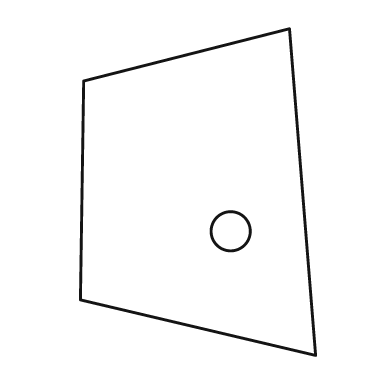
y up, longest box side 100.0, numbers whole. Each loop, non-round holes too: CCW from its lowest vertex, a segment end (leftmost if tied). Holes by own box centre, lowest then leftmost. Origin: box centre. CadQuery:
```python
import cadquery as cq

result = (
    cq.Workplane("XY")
    .moveTo(36.0, -50.0)
    .lineTo(28.0, 50.0)
    .lineTo(-35.0, 34.0)
    .lineTo(-36.0, -33.0)
    .close()
    .moveTo(10.0, -12.0)
    .circle(6.0)
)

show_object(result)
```